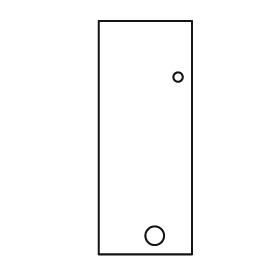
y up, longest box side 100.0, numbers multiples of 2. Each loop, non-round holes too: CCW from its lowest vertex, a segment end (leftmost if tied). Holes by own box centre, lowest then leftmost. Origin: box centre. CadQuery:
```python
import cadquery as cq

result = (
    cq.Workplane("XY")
    .moveTo(-20.0, -50.0)
    .lineTo(20.0, -50.0)
    .lineTo(20.0, 50.0)
    .lineTo(-20.0, 50.0)
    .close()
    .moveTo(4.0, -42.0)
    .circle(4.0)
    .moveTo(14.0, 26.0)
    .circle(2.0)
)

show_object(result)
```